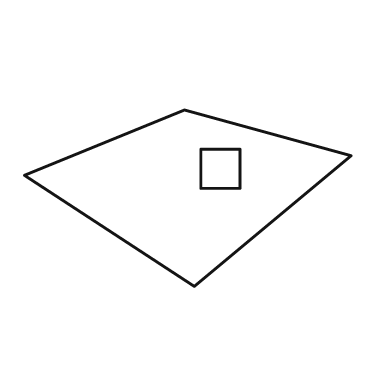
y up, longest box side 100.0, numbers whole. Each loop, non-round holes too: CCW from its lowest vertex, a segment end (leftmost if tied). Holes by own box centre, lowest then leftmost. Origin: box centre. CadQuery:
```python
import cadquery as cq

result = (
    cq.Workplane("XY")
    .moveTo(2.0, -27.0)
    .lineTo(50.0, 13.0)
    .lineTo(-1.0, 27.0)
    .lineTo(-50.0, 7.0)
    .close()
    .moveTo(4.0, 3.0)
    .lineTo(16.0, 3.0)
    .lineTo(16.0, 15.0)
    .lineTo(4.0, 15.0)
    .close()
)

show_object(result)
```